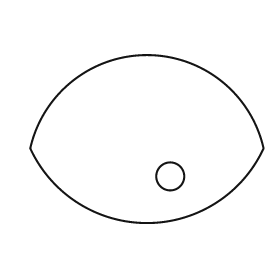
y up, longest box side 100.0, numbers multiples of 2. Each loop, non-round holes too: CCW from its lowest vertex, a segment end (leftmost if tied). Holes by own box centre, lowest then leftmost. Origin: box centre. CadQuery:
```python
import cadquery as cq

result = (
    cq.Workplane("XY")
    .moveTo(-50.0, -4.0)
    .threePointArc((0.0, -36.0), (50.0, -4.0))
    .threePointArc((0.0, 36.0), (-50.0, -4.0))
    .close()
    .moveTo(10.0, -16.0)
    .circle(6.0)
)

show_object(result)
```